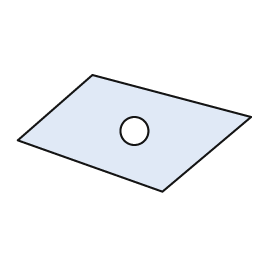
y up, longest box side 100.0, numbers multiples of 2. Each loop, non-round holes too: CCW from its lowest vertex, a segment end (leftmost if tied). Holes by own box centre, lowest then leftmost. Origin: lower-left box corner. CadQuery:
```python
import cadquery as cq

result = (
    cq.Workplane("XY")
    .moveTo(62.0, 0.0)
    .lineTo(100.0, 32.0)
    .lineTo(32.0, 50.0)
    .lineTo(0.0, 22.0)
    .close()
    .moveTo(50.0, 26.0)
    .circle(6.0)
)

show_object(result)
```